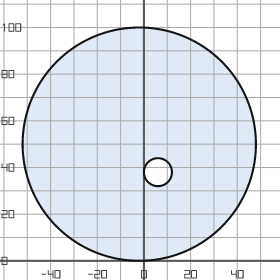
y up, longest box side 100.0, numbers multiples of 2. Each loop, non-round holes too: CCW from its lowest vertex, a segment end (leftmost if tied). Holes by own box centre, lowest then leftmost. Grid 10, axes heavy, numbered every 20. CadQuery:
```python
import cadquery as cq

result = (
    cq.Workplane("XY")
    .moveTo(-2.0, 50.0)
    .circle(50.0)
    .moveTo(6.0, 38.0)
    .circle(6.0)
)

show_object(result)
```